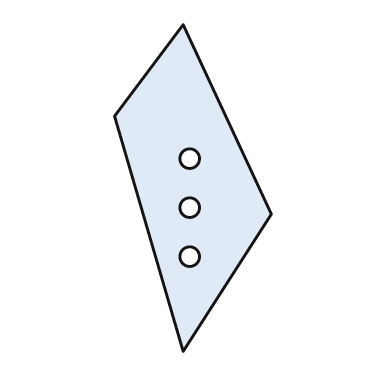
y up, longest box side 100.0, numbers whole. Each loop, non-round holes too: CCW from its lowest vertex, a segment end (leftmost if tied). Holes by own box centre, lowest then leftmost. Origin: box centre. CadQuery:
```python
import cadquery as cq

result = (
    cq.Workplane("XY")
    .moveTo(-3.0, -50.0)
    .lineTo(24.0, -8.0)
    .lineTo(-3.0, 50.0)
    .lineTo(-24.0, 22.0)
    .close()
    .moveTo(-1.0, -21.0)
    .circle(3.0)
    .moveTo(-1.0, -6.0)
    .circle(3.0)
    .moveTo(-1.0, 9.0)
    .circle(3.0)
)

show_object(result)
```